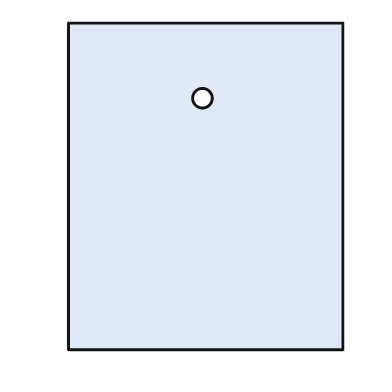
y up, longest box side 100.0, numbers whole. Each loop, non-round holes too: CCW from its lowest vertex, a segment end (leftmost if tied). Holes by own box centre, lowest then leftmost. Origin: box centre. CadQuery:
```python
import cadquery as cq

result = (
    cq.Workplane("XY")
    .moveTo(-42.0, -50.0)
    .lineTo(42.0, -50.0)
    .lineTo(42.0, 50.0)
    .lineTo(-42.0, 50.0)
    .close()
    .moveTo(-1.0, 27.0)
    .circle(3.0)
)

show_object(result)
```